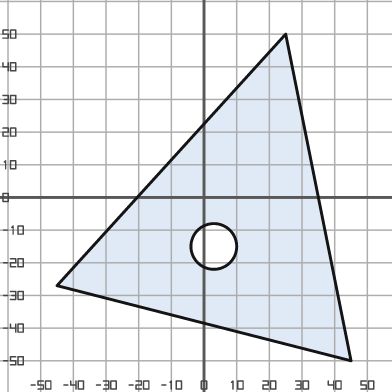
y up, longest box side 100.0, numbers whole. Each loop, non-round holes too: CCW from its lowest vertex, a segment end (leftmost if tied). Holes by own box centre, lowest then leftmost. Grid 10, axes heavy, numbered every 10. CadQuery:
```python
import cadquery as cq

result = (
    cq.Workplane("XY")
    .moveTo(45.0, -50.0)
    .lineTo(25.0, 50.0)
    .lineTo(-45.0, -27.0)
    .close()
    .moveTo(3.0, -15.0)
    .circle(7.0)
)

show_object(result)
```